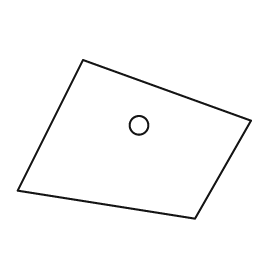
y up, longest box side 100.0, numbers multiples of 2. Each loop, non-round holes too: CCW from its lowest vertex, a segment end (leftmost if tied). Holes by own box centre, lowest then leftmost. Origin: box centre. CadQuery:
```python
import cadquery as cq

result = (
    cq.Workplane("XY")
    .moveTo(26.0, -34.0)
    .lineTo(50.0, 8.0)
    .lineTo(-22.0, 34.0)
    .lineTo(-50.0, -22.0)
    .close()
    .moveTo(2.0, 6.0)
    .circle(4.0)
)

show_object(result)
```